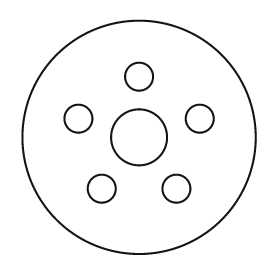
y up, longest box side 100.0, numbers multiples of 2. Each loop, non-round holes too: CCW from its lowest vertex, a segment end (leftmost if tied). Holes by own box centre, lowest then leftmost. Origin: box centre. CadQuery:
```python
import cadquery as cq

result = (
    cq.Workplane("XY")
    .moveTo(0.0, 0.0)
    .circle(50.0)
    .moveTo(-16.0, -22.0)
    .circle(6.0)
    .moveTo(16.0, -22.0)
    .circle(6.0)
    .moveTo(0.0, 0.0)
    .circle(12.0)
    .moveTo(-26.0, 8.0)
    .circle(6.0)
    .moveTo(26.0, 8.0)
    .circle(6.0)
    .moveTo(0.0, 26.0)
    .circle(6.0)
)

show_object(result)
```